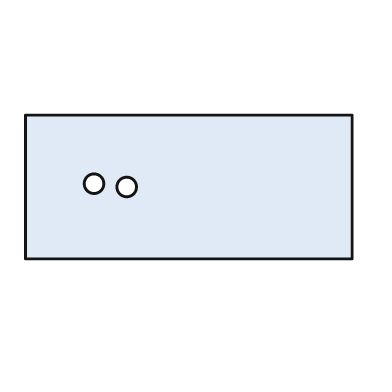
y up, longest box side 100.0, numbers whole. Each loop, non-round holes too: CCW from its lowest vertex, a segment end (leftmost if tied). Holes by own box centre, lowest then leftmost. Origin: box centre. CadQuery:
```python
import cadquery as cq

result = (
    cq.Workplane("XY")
    .moveTo(-50.0, -22.0)
    .lineTo(50.0, -22.0)
    .lineTo(50.0, 22.0)
    .lineTo(-50.0, 22.0)
    .close()
    .moveTo(-19.0, 0.0)
    .circle(3.0)
    .moveTo(-29.0, 1.0)
    .circle(3.0)
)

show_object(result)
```